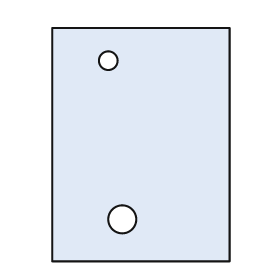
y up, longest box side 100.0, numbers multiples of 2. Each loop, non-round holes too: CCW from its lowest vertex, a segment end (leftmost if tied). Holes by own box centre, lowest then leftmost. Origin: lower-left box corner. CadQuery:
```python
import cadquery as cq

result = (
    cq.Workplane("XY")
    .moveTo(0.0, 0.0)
    .lineTo(76.0, 0.0)
    .lineTo(76.0, 100.0)
    .lineTo(0.0, 100.0)
    .close()
    .moveTo(30.0, 18.0)
    .circle(6.0)
    .moveTo(24.0, 86.0)
    .circle(4.0)
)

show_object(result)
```